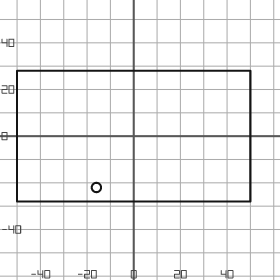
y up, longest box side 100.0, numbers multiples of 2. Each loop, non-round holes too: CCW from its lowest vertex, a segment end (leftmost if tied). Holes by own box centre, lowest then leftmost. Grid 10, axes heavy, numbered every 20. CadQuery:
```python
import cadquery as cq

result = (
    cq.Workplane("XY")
    .moveTo(-50.0, -28.0)
    .lineTo(50.0, -28.0)
    .lineTo(50.0, 28.0)
    .lineTo(-50.0, 28.0)
    .close()
    .moveTo(-16.0, -22.0)
    .circle(2.0)
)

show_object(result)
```